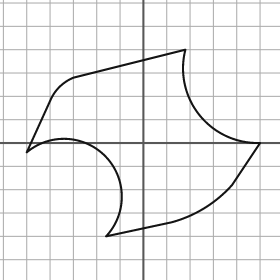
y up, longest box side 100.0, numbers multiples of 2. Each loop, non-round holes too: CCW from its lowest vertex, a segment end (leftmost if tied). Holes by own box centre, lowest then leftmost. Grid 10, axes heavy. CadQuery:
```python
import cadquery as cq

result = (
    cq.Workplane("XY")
    .moveTo(-16.0, -40.0)
    .lineTo(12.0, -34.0)
    .threePointArc((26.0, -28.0), (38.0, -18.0))
    .lineTo(50.0, 0.0)
    .threePointArc((24.0, 12.0), (18.0, 40.0))
    .lineTo(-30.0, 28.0)
    .threePointArc((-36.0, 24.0), (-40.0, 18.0))
    .lineTo(-50.0, -4.0)
    .threePointArc((-16.0, -6.0), (-16.0, -40.0))
    .close()
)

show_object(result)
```